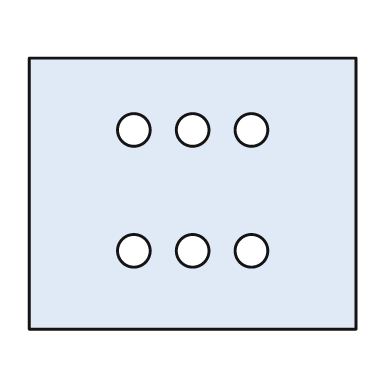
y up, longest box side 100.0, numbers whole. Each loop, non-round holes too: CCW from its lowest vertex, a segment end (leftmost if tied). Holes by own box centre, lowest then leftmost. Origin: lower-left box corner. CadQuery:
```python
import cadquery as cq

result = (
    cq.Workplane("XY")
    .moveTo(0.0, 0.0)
    .lineTo(100.0, 0.0)
    .lineTo(100.0, 83.0)
    .lineTo(0.0, 83.0)
    .close()
    .moveTo(32.0, 24.0)
    .circle(5.0)
    .moveTo(50.0, 24.0)
    .circle(5.0)
    .moveTo(68.0, 24.0)
    .circle(5.0)
    .moveTo(32.0, 61.0)
    .circle(5.0)
    .moveTo(50.0, 61.0)
    .circle(5.0)
    .moveTo(68.0, 61.0)
    .circle(5.0)
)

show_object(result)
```